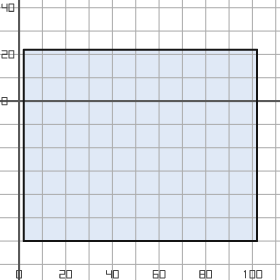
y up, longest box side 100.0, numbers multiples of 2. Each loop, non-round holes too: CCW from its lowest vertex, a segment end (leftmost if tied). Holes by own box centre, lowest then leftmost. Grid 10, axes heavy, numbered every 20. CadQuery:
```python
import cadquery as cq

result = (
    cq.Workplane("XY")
    .moveTo(2.0, -60.0)
    .lineTo(102.0, -60.0)
    .lineTo(102.0, 22.0)
    .lineTo(2.0, 22.0)
    .close()
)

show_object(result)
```